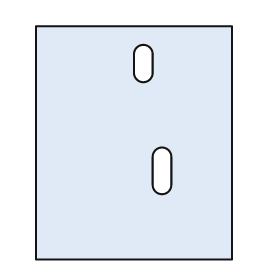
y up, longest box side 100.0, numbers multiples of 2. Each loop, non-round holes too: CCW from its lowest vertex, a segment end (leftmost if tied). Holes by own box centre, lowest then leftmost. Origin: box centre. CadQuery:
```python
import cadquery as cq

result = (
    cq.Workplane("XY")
    .moveTo(-42.0, -50.0)
    .lineTo(42.0, -50.0)
    .lineTo(42.0, 50.0)
    .lineTo(-42.0, 50.0)
    .close()
    .moveTo(8.0, -18.0)
    .threePointArc((12.0, -22.0), (16.0, -18.0))
    .lineTo(16.0, -6.0)
    .threePointArc((12.0, -2.0), (8.0, -6.0))
    .close()
    .moveTo(0.0, 30.0)
    .threePointArc((4.0, 26.0), (8.0, 30.0))
    .lineTo(8.0, 38.0)
    .threePointArc((4.0, 42.0), (0.0, 38.0))
    .close()
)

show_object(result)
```